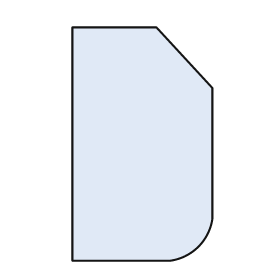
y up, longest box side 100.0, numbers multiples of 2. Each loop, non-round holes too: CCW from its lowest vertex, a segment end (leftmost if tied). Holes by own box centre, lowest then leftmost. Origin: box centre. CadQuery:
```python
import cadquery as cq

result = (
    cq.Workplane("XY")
    .moveTo(-30.0, -50.0)
    .lineTo(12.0, -50.0)
    .threePointArc((24.0, -44.0), (30.0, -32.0))
    .lineTo(30.0, 24.0)
    .lineTo(6.0, 50.0)
    .lineTo(-30.0, 50.0)
    .close()
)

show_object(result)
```